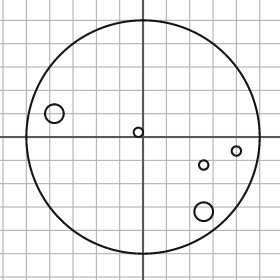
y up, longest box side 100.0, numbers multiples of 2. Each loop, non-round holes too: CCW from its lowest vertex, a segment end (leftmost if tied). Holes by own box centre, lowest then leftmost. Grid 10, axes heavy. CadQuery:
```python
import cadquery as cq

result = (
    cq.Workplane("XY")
    .moveTo(0.0, 0.0)
    .circle(50.0)
    .moveTo(26.0, -32.0)
    .circle(4.0)
    .moveTo(26.0, -12.0)
    .circle(2.0)
    .moveTo(40.0, -6.0)
    .circle(2.0)
    .moveTo(-2.0, 2.0)
    .circle(2.0)
    .moveTo(-38.0, 10.0)
    .circle(4.0)
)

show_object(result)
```